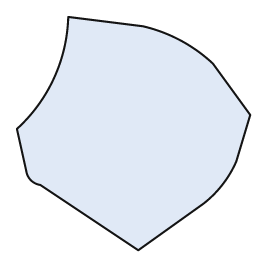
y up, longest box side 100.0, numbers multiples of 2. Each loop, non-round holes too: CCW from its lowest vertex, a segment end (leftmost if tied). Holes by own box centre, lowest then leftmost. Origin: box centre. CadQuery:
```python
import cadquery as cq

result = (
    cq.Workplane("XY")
    .moveTo(2.0, -50.0)
    .lineTo(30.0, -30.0)
    .threePointArc((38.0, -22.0), (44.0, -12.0))
    .lineTo(50.0, 8.0)
    .lineTo(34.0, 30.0)
    .threePointArc((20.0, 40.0), (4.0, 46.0))
    .lineTo(-28.0, 50.0)
    .threePointArc((-34.0, 24.0), (-50.0, 2.0))
    .lineTo(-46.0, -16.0)
    .threePointArc((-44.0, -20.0), (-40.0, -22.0))
    .close()
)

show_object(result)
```